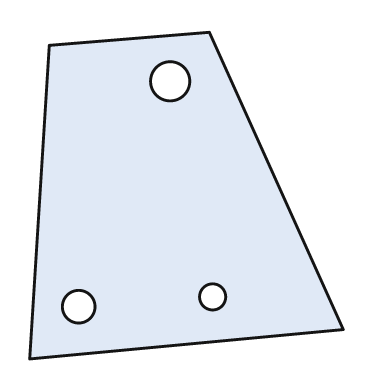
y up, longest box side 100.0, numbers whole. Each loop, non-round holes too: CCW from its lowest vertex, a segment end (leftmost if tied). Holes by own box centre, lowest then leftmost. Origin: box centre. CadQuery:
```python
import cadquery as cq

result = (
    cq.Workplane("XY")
    .moveTo(-48.0, -50.0)
    .lineTo(48.0, -41.0)
    .lineTo(7.0, 50.0)
    .lineTo(-42.0, 46.0)
    .close()
    .moveTo(-33.0, -34.0)
    .circle(5.0)
    .moveTo(8.0, -31.0)
    .circle(4.0)
    .moveTo(-5.0, 35.0)
    .circle(6.0)
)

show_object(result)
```